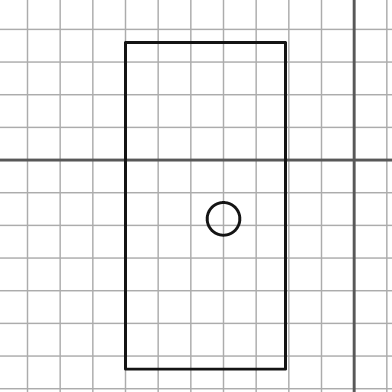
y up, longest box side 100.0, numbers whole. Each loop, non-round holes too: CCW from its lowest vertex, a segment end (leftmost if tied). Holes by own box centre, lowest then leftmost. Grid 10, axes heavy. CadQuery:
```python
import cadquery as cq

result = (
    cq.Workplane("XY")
    .moveTo(-70.0, -64.0)
    .lineTo(-21.0, -64.0)
    .lineTo(-21.0, 36.0)
    .lineTo(-70.0, 36.0)
    .close()
    .moveTo(-40.0, -18.0)
    .circle(5.0)
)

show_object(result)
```